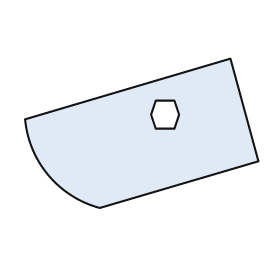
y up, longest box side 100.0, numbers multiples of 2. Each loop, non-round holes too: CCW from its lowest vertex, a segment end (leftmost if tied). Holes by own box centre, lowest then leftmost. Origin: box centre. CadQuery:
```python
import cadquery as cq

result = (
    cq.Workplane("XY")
    .moveTo(-18.0, -32.0)
    .lineTo(50.0, -12.0)
    .lineTo(38.0, 32.0)
    .lineTo(-50.0, 6.0)
    .threePointArc((-40.0, -18.0), (-18.0, -32.0))
    .close()
    .moveTo(6.0, 2.0)
    .lineTo(14.0, 2.0)
    .lineTo(16.0, 8.0)
    .lineTo(14.0, 14.0)
    .lineTo(6.0, 14.0)
    .lineTo(4.0, 8.0)
    .close()
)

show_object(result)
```